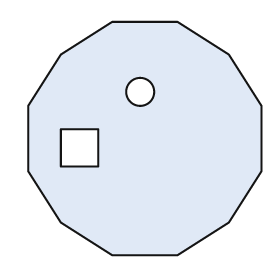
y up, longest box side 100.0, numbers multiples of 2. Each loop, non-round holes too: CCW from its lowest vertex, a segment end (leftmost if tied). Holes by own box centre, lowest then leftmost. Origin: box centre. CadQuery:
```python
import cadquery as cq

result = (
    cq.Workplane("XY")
    .moveTo(-14.0, -50.0)
    .lineTo(14.0, -50.0)
    .lineTo(36.0, -36.0)
    .lineTo(50.0, -14.0)
    .lineTo(50.0, 14.0)
    .lineTo(36.0, 36.0)
    .lineTo(14.0, 50.0)
    .lineTo(-14.0, 50.0)
    .lineTo(-36.0, 36.0)
    .lineTo(-50.0, 14.0)
    .lineTo(-50.0, -14.0)
    .lineTo(-36.0, -36.0)
    .close()
    .moveTo(-36.0, -12.0)
    .lineTo(-20.0, -12.0)
    .lineTo(-20.0, 4.0)
    .lineTo(-36.0, 4.0)
    .close()
    .moveTo(-2.0, 20.0)
    .circle(6.0)
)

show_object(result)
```